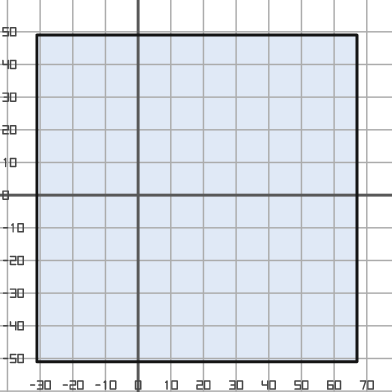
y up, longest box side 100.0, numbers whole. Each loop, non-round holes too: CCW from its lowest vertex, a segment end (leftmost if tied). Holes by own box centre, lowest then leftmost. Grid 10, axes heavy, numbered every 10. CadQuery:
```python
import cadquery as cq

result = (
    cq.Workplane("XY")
    .moveTo(-31.0, -51.0)
    .lineTo(67.0, -51.0)
    .lineTo(67.0, 49.0)
    .lineTo(-31.0, 49.0)
    .close()
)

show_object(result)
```